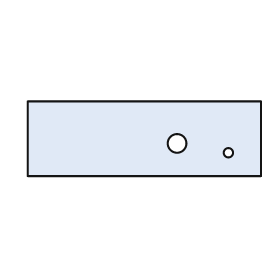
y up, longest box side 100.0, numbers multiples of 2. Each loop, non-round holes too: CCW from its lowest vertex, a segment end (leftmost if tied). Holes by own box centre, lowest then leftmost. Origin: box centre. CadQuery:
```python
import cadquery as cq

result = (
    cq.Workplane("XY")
    .moveTo(-50.0, -16.0)
    .lineTo(50.0, -16.0)
    .lineTo(50.0, 16.0)
    .lineTo(-50.0, 16.0)
    .close()
    .moveTo(36.0, -6.0)
    .circle(2.0)
    .moveTo(14.0, -2.0)
    .circle(4.0)
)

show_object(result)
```